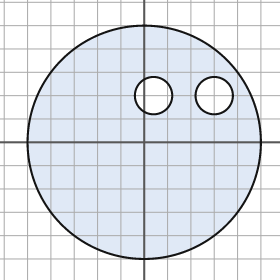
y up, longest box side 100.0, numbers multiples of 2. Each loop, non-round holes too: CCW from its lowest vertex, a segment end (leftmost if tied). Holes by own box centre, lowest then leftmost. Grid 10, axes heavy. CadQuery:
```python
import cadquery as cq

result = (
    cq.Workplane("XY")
    .moveTo(0.0, 0.0)
    .circle(50.0)
    .moveTo(4.0, 20.0)
    .circle(8.0)
    .moveTo(30.0, 20.0)
    .circle(8.0)
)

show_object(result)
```